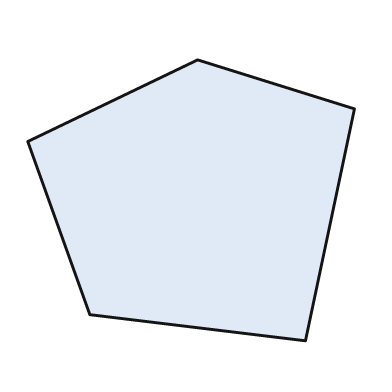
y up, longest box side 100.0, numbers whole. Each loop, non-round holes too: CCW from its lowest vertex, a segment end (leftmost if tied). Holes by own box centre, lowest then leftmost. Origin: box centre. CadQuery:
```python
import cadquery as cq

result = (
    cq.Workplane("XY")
    .moveTo(35.0, -43.0)
    .lineTo(50.0, 28.0)
    .lineTo(2.0, 43.0)
    .lineTo(-50.0, 18.0)
    .lineTo(-31.0, -35.0)
    .close()
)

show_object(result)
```